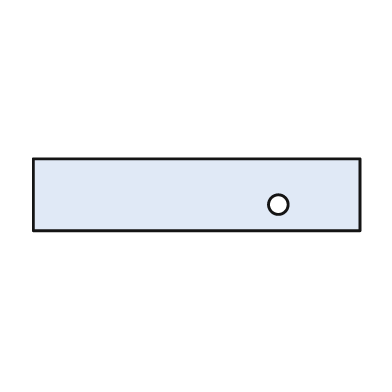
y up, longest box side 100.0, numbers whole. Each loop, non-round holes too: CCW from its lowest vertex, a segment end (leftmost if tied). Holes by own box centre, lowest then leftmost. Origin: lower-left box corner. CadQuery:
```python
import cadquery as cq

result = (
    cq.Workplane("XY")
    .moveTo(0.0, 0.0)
    .lineTo(100.0, 0.0)
    .lineTo(100.0, 22.0)
    .lineTo(0.0, 22.0)
    .close()
    .moveTo(75.0, 8.0)
    .circle(3.0)
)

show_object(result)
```